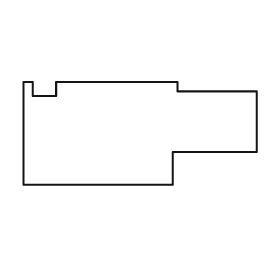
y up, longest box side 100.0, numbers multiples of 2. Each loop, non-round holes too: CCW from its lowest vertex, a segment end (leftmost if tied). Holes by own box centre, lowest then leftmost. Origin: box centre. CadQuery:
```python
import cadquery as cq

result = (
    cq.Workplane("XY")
    .moveTo(-50.0, -22.0)
    .lineTo(14.0, -22.0)
    .lineTo(14.0, -8.0)
    .lineTo(50.0, -8.0)
    .lineTo(50.0, 18.0)
    .lineTo(16.0, 18.0)
    .lineTo(16.0, 22.0)
    .lineTo(-36.0, 22.0)
    .lineTo(-36.0, 16.0)
    .lineTo(-46.0, 16.0)
    .lineTo(-46.0, 22.0)
    .lineTo(-50.0, 22.0)
    .close()
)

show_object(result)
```